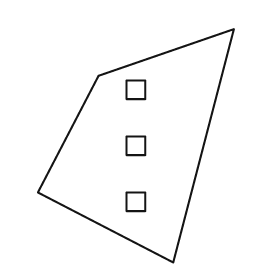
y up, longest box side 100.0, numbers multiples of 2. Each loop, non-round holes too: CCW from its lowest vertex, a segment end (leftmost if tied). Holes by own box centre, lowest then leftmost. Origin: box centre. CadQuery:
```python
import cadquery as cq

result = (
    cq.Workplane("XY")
    .moveTo(16.0, -50.0)
    .lineTo(42.0, 50.0)
    .lineTo(-16.0, 30.0)
    .lineTo(-42.0, -20.0)
    .close()
    .moveTo(-4.0, -28.0)
    .lineTo(4.0, -28.0)
    .lineTo(4.0, -20.0)
    .lineTo(-4.0, -20.0)
    .close()
    .moveTo(-4.0, -4.0)
    .lineTo(4.0, -4.0)
    .lineTo(4.0, 4.0)
    .lineTo(-4.0, 4.0)
    .close()
    .moveTo(-4.0, 20.0)
    .lineTo(4.0, 20.0)
    .lineTo(4.0, 28.0)
    .lineTo(-4.0, 28.0)
    .close()
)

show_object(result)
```